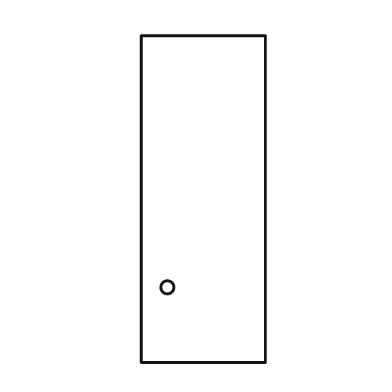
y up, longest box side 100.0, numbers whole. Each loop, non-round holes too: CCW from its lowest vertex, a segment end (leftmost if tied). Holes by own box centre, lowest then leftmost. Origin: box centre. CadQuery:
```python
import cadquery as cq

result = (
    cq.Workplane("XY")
    .moveTo(-19.0, -50.0)
    .lineTo(19.0, -50.0)
    .lineTo(19.0, 50.0)
    .lineTo(-19.0, 50.0)
    .close()
    .moveTo(-11.0, -27.0)
    .circle(2.0)
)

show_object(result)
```